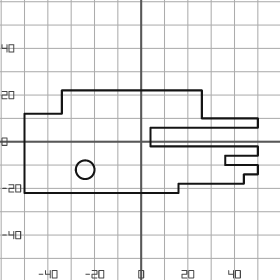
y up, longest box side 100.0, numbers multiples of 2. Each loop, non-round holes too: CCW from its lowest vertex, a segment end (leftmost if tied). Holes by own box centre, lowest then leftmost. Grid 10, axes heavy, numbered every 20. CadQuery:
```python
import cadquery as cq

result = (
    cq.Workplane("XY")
    .moveTo(-50.0, -22.0)
    .lineTo(16.0, -22.0)
    .lineTo(16.0, -18.0)
    .lineTo(44.0, -18.0)
    .lineTo(44.0, -14.0)
    .lineTo(50.0, -14.0)
    .lineTo(50.0, -10.0)
    .lineTo(36.0, -10.0)
    .lineTo(36.0, -6.0)
    .lineTo(50.0, -6.0)
    .lineTo(50.0, -2.0)
    .lineTo(4.0, -2.0)
    .lineTo(4.0, 6.0)
    .lineTo(50.0, 6.0)
    .lineTo(50.0, 10.0)
    .lineTo(26.0, 10.0)
    .lineTo(26.0, 22.0)
    .lineTo(-34.0, 22.0)
    .lineTo(-34.0, 12.0)
    .lineTo(-50.0, 12.0)
    .close()
    .moveTo(-24.0, -12.0)
    .circle(4.0)
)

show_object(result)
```